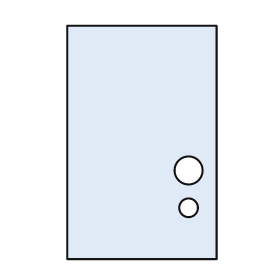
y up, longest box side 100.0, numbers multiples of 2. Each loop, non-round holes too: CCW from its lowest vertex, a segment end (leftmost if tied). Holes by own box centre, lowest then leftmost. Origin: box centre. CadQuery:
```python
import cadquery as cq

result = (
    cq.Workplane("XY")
    .moveTo(-32.0, -50.0)
    .lineTo(32.0, -50.0)
    .lineTo(32.0, 50.0)
    .lineTo(-32.0, 50.0)
    .close()
    .moveTo(20.0, -28.0)
    .circle(4.0)
    .moveTo(20.0, -12.0)
    .circle(6.0)
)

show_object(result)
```